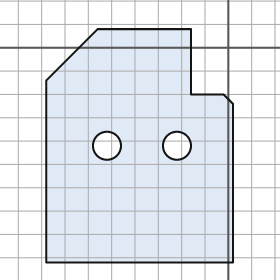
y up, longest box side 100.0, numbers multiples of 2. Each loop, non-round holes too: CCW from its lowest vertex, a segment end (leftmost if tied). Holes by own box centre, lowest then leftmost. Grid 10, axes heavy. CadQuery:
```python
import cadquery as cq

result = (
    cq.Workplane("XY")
    .moveTo(-78.0, -92.0)
    .lineTo(2.0, -92.0)
    .lineTo(2.0, -24.0)
    .lineTo(-2.0, -20.0)
    .lineTo(-16.0, -20.0)
    .lineTo(-16.0, 8.0)
    .lineTo(-56.0, 8.0)
    .lineTo(-78.0, -14.0)
    .close()
    .moveTo(-52.0, -42.0)
    .circle(6.0)
    .moveTo(-22.0, -42.0)
    .circle(6.0)
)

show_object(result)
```